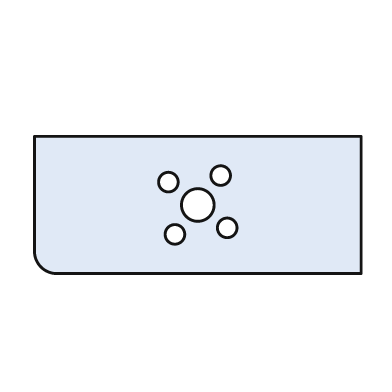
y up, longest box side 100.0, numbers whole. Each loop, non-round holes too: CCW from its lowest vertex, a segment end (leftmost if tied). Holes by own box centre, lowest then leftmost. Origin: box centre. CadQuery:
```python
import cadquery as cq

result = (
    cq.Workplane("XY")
    .moveTo(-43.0, -21.0)
    .lineTo(50.0, -21.0)
    .lineTo(50.0, 21.0)
    .lineTo(-50.0, 21.0)
    .lineTo(-50.0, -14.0)
    .threePointArc((-48.0, -19.0), (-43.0, -21.0))
    .close()
    .moveTo(-7.0, -9.0)
    .circle(3.0)
    .moveTo(9.0, -7.0)
    .circle(3.0)
    .moveTo(0.0, 0.0)
    .circle(5.0)
    .moveTo(-9.0, 7.0)
    .circle(3.0)
    .moveTo(7.0, 9.0)
    .circle(3.0)
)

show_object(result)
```